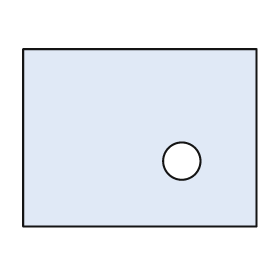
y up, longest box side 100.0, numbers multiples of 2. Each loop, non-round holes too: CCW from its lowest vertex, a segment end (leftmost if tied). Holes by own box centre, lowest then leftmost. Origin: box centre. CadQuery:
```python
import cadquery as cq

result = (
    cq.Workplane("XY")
    .moveTo(-50.0, -38.0)
    .lineTo(50.0, -38.0)
    .lineTo(50.0, 38.0)
    .lineTo(-50.0, 38.0)
    .close()
    .moveTo(18.0, -10.0)
    .circle(8.0)
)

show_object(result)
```